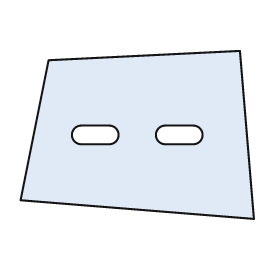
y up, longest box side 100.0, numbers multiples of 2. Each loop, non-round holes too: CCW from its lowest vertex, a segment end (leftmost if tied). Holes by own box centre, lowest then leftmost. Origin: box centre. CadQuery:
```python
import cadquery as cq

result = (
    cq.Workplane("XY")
    .moveTo(50.0, -36.0)
    .lineTo(44.0, 36.0)
    .lineTo(-38.0, 32.0)
    .lineTo(-50.0, -28.0)
    .close()
    .moveTo(-24.0, -4.0)
    .lineTo(-12.0, -4.0)
    .threePointArc((-8.0, 0.0), (-12.0, 4.0))
    .lineTo(-24.0, 4.0)
    .threePointArc((-28.0, 0.0), (-24.0, -4.0))
    .close()
    .moveTo(12.0, -4.0)
    .lineTo(24.0, -4.0)
    .threePointArc((28.0, 0.0), (24.0, 4.0))
    .lineTo(12.0, 4.0)
    .threePointArc((8.0, 0.0), (12.0, -4.0))
    .close()
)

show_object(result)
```